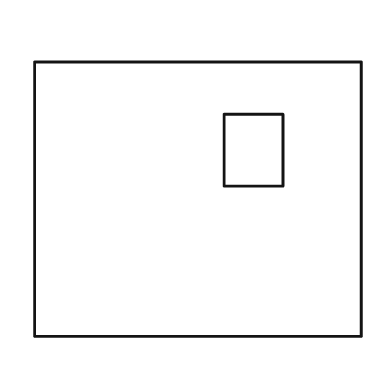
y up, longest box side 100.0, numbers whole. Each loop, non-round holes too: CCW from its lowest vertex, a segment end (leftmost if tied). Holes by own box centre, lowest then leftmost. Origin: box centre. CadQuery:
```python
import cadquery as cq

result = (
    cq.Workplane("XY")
    .moveTo(-50.0, -42.0)
    .lineTo(50.0, -42.0)
    .lineTo(50.0, 42.0)
    .lineTo(-50.0, 42.0)
    .close()
    .moveTo(8.0, 4.0)
    .lineTo(26.0, 4.0)
    .lineTo(26.0, 26.0)
    .lineTo(8.0, 26.0)
    .close()
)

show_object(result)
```